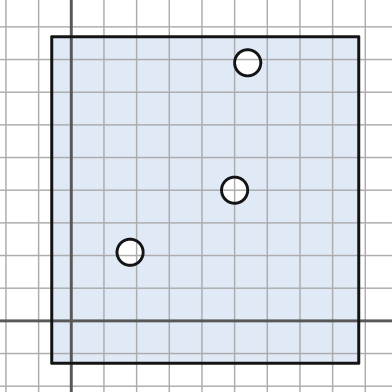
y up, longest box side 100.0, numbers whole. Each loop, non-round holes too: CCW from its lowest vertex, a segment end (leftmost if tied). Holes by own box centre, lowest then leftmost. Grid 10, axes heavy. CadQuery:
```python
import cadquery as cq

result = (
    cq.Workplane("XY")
    .moveTo(-6.0, -13.0)
    .lineTo(88.0, -13.0)
    .lineTo(88.0, 87.0)
    .lineTo(-6.0, 87.0)
    .close()
    .moveTo(18.0, 21.0)
    .circle(4.0)
    .moveTo(50.0, 40.0)
    .circle(4.0)
    .moveTo(54.0, 79.0)
    .circle(4.0)
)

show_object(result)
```